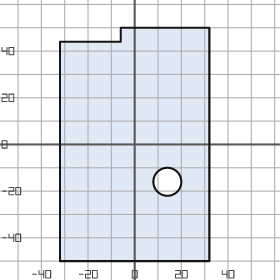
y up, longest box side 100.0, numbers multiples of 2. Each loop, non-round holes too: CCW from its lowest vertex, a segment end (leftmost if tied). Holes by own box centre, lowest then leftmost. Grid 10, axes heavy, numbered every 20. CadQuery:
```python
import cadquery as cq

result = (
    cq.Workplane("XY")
    .moveTo(-32.0, -50.0)
    .lineTo(32.0, -50.0)
    .lineTo(32.0, 50.0)
    .lineTo(-6.0, 50.0)
    .lineTo(-6.0, 44.0)
    .lineTo(-32.0, 44.0)
    .close()
    .moveTo(14.0, -16.0)
    .circle(6.0)
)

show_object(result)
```